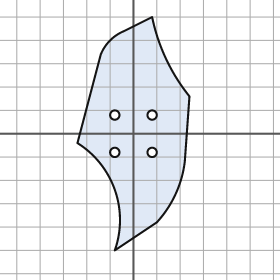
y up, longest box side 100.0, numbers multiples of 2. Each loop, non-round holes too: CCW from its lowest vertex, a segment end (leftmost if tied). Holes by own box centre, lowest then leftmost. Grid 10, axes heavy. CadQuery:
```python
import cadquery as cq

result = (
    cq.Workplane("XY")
    .moveTo(-8.0, -50.0)
    .lineTo(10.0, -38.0)
    .threePointArc((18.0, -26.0), (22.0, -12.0))
    .lineTo(24.0, 16.0)
    .threePointArc((14.0, 32.0), (8.0, 50.0))
    .lineTo(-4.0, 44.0)
    .threePointArc((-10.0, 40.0), (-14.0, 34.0))
    .lineTo(-24.0, -4.0)
    .threePointArc((-8.0, -24.0), (-8.0, -50.0))
    .close()
    .moveTo(-8.0, -8.0)
    .circle(2.0)
    .moveTo(8.0, -8.0)
    .circle(2.0)
    .moveTo(-8.0, 8.0)
    .circle(2.0)
    .moveTo(8.0, 8.0)
    .circle(2.0)
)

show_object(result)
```